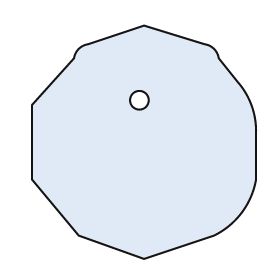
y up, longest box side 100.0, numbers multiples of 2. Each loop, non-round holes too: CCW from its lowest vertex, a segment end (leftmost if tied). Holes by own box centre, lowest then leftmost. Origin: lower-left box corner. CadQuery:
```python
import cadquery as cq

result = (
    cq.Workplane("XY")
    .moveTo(48.0, 0.0)
    .lineTo(78.0, 10.0)
    .threePointArc((90.0, 20.0), (96.0, 34.0))
    .lineTo(96.0, 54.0)
    .threePointArc((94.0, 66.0), (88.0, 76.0))
    .lineTo(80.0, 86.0)
    .threePointArc((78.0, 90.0), (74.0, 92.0))
    .lineTo(48.0, 100.0)
    .lineTo(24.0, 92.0)
    .threePointArc((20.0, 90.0), (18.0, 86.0))
    .lineTo(0.0, 66.0)
    .lineTo(0.0, 34.0)
    .lineTo(20.0, 10.0)
    .close()
    .moveTo(46.0, 68.0)
    .circle(4.0)
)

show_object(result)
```